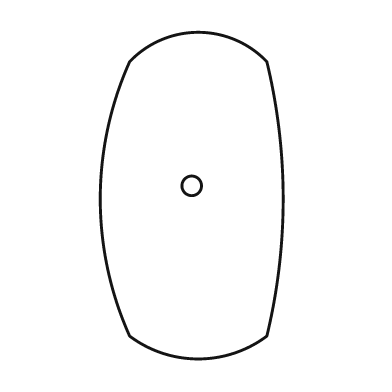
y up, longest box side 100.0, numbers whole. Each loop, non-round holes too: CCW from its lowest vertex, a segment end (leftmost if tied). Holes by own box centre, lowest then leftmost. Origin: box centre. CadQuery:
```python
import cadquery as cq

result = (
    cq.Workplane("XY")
    .moveTo(-19.0, -43.0)
    .threePointArc((2.0, -50.0), (23.0, -43.0))
    .threePointArc((28.0, -1.0), (23.0, 41.0))
    .threePointArc((2.0, 50.0), (-19.0, 41.0))
    .threePointArc((-28.0, -1.0), (-19.0, -43.0))
    .close()
    .moveTo(0.0, 3.0)
    .circle(3.0)
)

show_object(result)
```